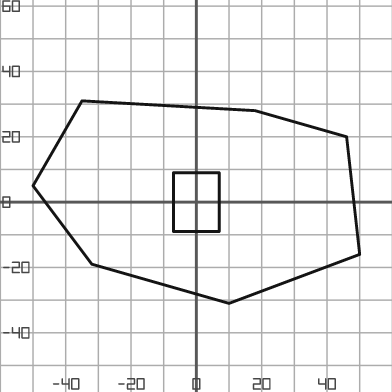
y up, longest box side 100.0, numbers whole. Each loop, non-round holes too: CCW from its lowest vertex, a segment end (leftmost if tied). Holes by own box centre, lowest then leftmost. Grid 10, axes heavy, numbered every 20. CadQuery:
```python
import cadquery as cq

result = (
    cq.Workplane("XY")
    .moveTo(10.0, -31.0)
    .lineTo(50.0, -16.0)
    .lineTo(46.0, 20.0)
    .lineTo(18.0, 28.0)
    .lineTo(-35.0, 31.0)
    .lineTo(-50.0, 5.0)
    .lineTo(-32.0, -19.0)
    .close()
    .moveTo(-7.0, -9.0)
    .lineTo(7.0, -9.0)
    .lineTo(7.0, 9.0)
    .lineTo(-7.0, 9.0)
    .close()
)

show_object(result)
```